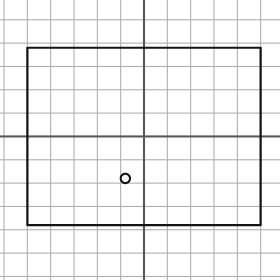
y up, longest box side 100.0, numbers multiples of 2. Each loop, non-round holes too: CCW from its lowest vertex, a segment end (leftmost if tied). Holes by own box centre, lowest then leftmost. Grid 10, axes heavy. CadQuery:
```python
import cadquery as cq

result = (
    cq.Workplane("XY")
    .moveTo(-50.0, -38.0)
    .lineTo(50.0, -38.0)
    .lineTo(50.0, 38.0)
    .lineTo(-50.0, 38.0)
    .close()
    .moveTo(-8.0, -18.0)
    .circle(2.0)
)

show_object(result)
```